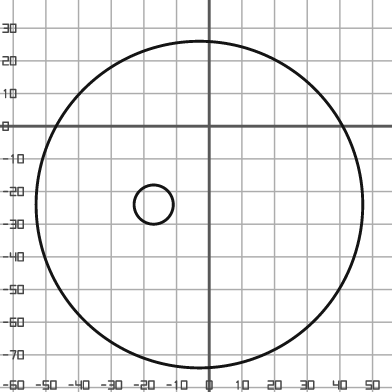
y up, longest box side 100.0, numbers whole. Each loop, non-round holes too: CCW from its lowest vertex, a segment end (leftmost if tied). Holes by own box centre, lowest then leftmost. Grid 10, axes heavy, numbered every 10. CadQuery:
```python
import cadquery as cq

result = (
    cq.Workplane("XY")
    .moveTo(-3.0, -24.0)
    .circle(50.0)
    .moveTo(-17.0, -24.0)
    .circle(6.0)
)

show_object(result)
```